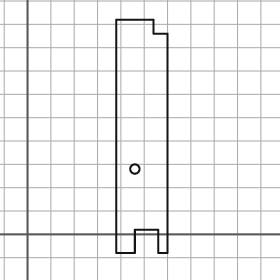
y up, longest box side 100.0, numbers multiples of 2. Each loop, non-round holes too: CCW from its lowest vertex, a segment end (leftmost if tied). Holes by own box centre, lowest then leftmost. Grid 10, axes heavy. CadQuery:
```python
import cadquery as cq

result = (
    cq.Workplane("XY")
    .moveTo(38.0, -8.0)
    .lineTo(46.0, -8.0)
    .lineTo(46.0, 2.0)
    .lineTo(56.0, 2.0)
    .lineTo(56.0, -8.0)
    .lineTo(60.0, -8.0)
    .lineTo(60.0, 86.0)
    .lineTo(54.0, 86.0)
    .lineTo(54.0, 92.0)
    .lineTo(38.0, 92.0)
    .close()
    .moveTo(46.0, 28.0)
    .circle(2.0)
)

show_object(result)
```